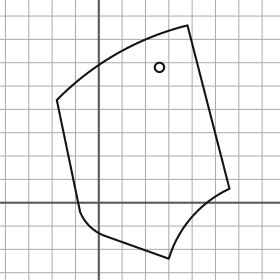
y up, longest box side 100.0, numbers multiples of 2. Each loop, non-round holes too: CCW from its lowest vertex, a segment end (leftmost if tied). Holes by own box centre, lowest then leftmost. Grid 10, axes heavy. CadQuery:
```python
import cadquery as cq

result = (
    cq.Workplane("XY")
    .moveTo(30.0, -24.0)
    .threePointArc((40.0, -6.0), (56.0, 6.0))
    .lineTo(38.0, 76.0)
    .threePointArc((8.0, 64.0), (-18.0, 44.0))
    .lineTo(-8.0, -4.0)
    .threePointArc((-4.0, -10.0), (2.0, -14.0))
    .close()
    .moveTo(26.0, 58.0)
    .circle(2.0)
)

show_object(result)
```